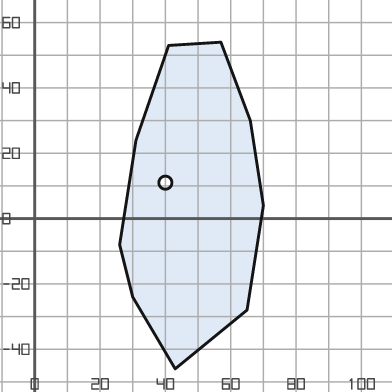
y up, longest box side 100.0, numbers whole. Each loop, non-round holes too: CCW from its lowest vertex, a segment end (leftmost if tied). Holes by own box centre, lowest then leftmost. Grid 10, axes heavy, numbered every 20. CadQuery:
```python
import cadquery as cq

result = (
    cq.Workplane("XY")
    .moveTo(43.0, -46.0)
    .lineTo(65.0, -28.0)
    .lineTo(70.0, 4.0)
    .lineTo(66.0, 30.0)
    .lineTo(57.0, 54.0)
    .lineTo(41.0, 53.0)
    .lineTo(31.0, 24.0)
    .lineTo(26.0, -8.0)
    .lineTo(30.0, -24.0)
    .close()
    .moveTo(40.0, 11.0)
    .circle(2.0)
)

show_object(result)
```